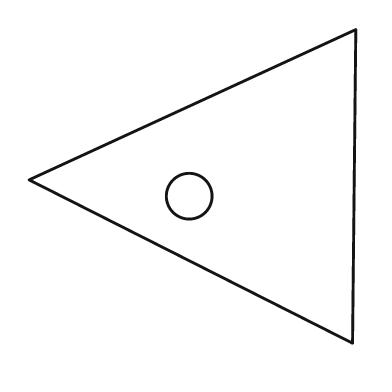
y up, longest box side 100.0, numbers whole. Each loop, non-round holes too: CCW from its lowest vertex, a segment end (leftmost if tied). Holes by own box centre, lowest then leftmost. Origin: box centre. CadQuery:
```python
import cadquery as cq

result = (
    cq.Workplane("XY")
    .moveTo(49.0, -48.0)
    .lineTo(50.0, 48.0)
    .lineTo(-50.0, 2.0)
    .close()
    .moveTo(-1.0, -3.0)
    .circle(7.0)
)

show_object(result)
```